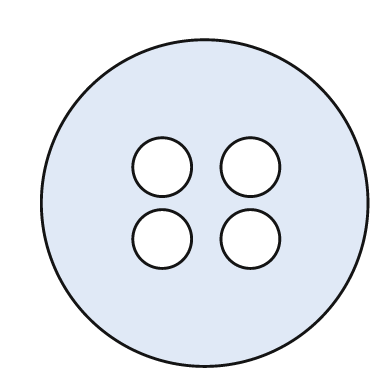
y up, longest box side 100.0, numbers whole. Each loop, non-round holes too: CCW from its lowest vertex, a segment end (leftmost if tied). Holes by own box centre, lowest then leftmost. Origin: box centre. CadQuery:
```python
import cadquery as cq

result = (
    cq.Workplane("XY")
    .moveTo(0.0, 0.0)
    .circle(50.0)
    .moveTo(-13.0, -11.0)
    .circle(9.0)
    .moveTo(14.0, -11.0)
    .circle(9.0)
    .moveTo(-13.0, 11.0)
    .circle(9.0)
    .moveTo(14.0, 11.0)
    .circle(9.0)
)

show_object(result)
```